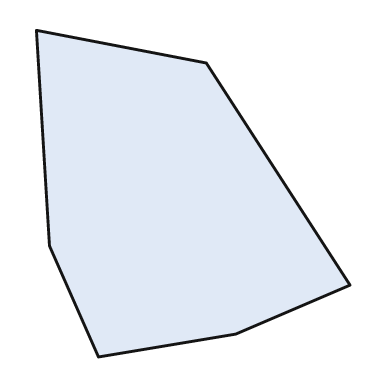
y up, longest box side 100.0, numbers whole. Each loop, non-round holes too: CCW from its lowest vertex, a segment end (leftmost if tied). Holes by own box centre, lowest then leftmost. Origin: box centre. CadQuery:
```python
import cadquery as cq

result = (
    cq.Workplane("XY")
    .moveTo(-29.0, -50.0)
    .lineTo(13.0, -43.0)
    .lineTo(48.0, -28.0)
    .lineTo(4.0, 40.0)
    .lineTo(-48.0, 50.0)
    .lineTo(-44.0, -16.0)
    .close()
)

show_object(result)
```